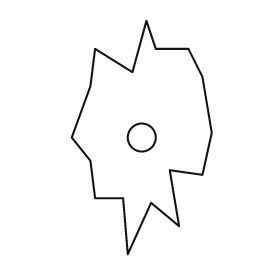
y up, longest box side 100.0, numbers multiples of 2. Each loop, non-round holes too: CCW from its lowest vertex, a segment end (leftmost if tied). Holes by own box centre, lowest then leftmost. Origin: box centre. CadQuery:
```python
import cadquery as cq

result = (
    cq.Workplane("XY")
    .moveTo(-6.0, -50.0)
    .lineTo(4.0, -28.0)
    .lineTo(16.0, -38.0)
    .lineTo(12.0, -14.0)
    .lineTo(26.0, -16.0)
    .lineTo(30.0, 2.0)
    .lineTo(26.0, 26.0)
    .lineTo(20.0, 38.0)
    .lineTo(6.0, 38.0)
    .lineTo(2.0, 50.0)
    .lineTo(-4.0, 28.0)
    .lineTo(-20.0, 38.0)
    .lineTo(-22.0, 22.0)
    .lineTo(-30.0, 0.0)
    .lineTo(-22.0, -10.0)
    .lineTo(-20.0, -26.0)
    .lineTo(-8.0, -26.0)
    .close()
    .moveTo(0.0, 0.0)
    .circle(6.0)
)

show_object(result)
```